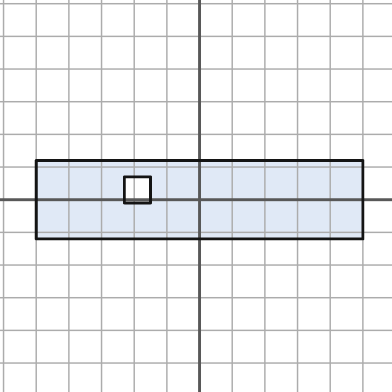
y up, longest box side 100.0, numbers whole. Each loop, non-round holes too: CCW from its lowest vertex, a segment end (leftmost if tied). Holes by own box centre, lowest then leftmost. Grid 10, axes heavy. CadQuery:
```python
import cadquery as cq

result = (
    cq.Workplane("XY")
    .moveTo(-50.0, -12.0)
    .lineTo(50.0, -12.0)
    .lineTo(50.0, 12.0)
    .lineTo(-50.0, 12.0)
    .close()
    .moveTo(-23.0, -1.0)
    .lineTo(-15.0, -1.0)
    .lineTo(-15.0, 7.0)
    .lineTo(-23.0, 7.0)
    .close()
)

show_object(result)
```